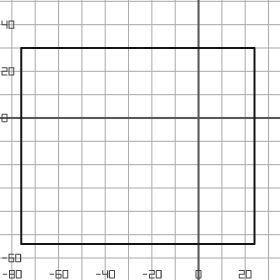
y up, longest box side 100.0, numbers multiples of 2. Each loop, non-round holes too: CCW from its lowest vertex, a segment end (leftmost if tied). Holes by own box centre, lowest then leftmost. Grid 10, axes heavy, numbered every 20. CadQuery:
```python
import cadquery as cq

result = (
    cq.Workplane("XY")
    .moveTo(-76.0, -54.0)
    .lineTo(24.0, -54.0)
    .lineTo(24.0, 30.0)
    .lineTo(-76.0, 30.0)
    .close()
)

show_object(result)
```